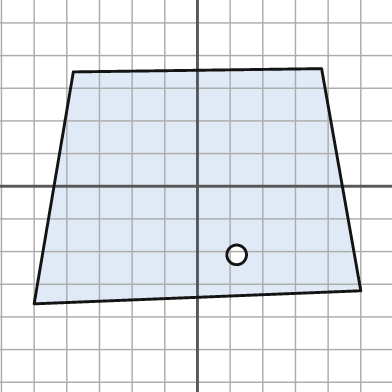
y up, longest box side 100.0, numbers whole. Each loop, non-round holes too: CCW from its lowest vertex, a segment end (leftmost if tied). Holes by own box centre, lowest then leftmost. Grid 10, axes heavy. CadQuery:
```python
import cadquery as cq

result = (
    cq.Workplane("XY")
    .moveTo(-50.0, -36.0)
    .lineTo(50.0, -32.0)
    .lineTo(38.0, 36.0)
    .lineTo(-38.0, 35.0)
    .close()
    .moveTo(12.0, -21.0)
    .circle(3.0)
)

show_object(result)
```